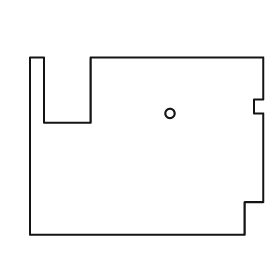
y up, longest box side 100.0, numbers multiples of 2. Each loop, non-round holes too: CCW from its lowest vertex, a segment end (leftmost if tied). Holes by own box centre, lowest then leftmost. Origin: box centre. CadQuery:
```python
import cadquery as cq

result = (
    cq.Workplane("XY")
    .moveTo(-50.0, -38.0)
    .lineTo(42.0, -38.0)
    .lineTo(42.0, -24.0)
    .lineTo(50.0, -24.0)
    .lineTo(50.0, 14.0)
    .lineTo(46.0, 14.0)
    .lineTo(46.0, 20.0)
    .lineTo(50.0, 20.0)
    .lineTo(50.0, 38.0)
    .lineTo(-24.0, 38.0)
    .lineTo(-24.0, 10.0)
    .lineTo(-44.0, 10.0)
    .lineTo(-44.0, 38.0)
    .lineTo(-50.0, 38.0)
    .close()
    .moveTo(10.0, 14.0)
    .circle(2.0)
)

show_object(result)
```